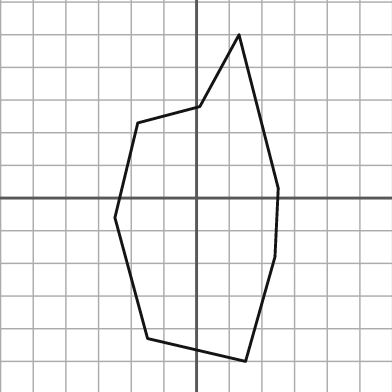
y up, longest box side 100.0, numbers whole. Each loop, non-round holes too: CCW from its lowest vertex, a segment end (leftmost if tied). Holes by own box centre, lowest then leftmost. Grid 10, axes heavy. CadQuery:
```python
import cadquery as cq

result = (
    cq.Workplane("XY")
    .moveTo(15.0, -50.0)
    .lineTo(24.0, -18.0)
    .lineTo(25.0, 3.0)
    .lineTo(13.0, 50.0)
    .lineTo(1.0, 28.0)
    .lineTo(-18.0, 23.0)
    .lineTo(-25.0, -6.0)
    .lineTo(-15.0, -43.0)
    .close()
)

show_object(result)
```